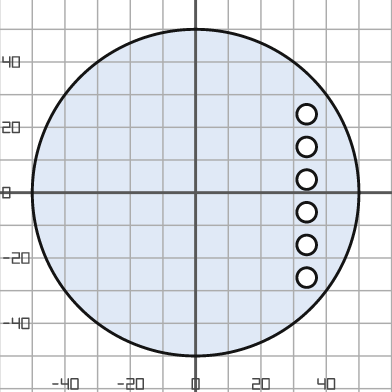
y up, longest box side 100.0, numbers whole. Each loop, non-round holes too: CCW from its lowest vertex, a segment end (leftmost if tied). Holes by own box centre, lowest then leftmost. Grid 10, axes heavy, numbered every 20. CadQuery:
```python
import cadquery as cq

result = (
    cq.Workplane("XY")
    .moveTo(0.0, 0.0)
    .circle(50.0)
    .moveTo(34.0, -26.0)
    .circle(3.0)
    .moveTo(34.0, -16.0)
    .circle(3.0)
    .moveTo(34.0, -6.0)
    .circle(3.0)
    .moveTo(34.0, 4.0)
    .circle(3.0)
    .moveTo(34.0, 14.0)
    .circle(3.0)
    .moveTo(34.0, 24.0)
    .circle(3.0)
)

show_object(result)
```